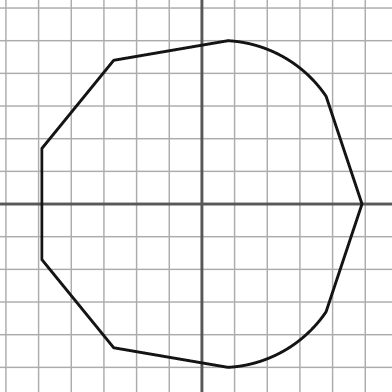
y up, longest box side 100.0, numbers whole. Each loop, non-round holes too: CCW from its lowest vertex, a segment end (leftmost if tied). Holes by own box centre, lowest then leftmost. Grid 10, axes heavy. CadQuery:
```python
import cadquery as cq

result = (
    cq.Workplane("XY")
    .moveTo(8.0, -50.0)
    .threePointArc((25.0, -45.0), (38.0, -33.0))
    .lineTo(49.0, 0.0)
    .lineTo(38.0, 33.0)
    .threePointArc((25.0, 45.0), (8.0, 50.0))
    .lineTo(-27.0, 44.0)
    .lineTo(-49.0, 17.0)
    .lineTo(-49.0, -17.0)
    .lineTo(-27.0, -44.0)
    .close()
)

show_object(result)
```